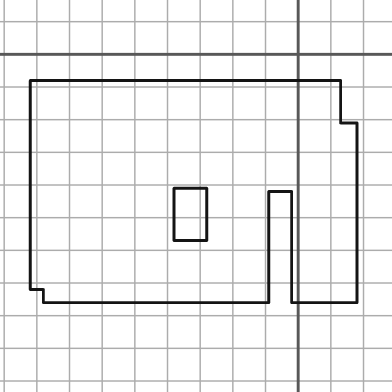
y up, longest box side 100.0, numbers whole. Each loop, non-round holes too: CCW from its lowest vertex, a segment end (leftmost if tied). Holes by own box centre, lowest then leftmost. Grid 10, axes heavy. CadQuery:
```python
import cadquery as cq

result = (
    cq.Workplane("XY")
    .moveTo(-78.0, -76.0)
    .lineTo(-9.0, -76.0)
    .lineTo(-9.0, -42.0)
    .lineTo(-2.0, -42.0)
    .lineTo(-2.0, -76.0)
    .lineTo(18.0, -76.0)
    .lineTo(18.0, -21.0)
    .lineTo(13.0, -21.0)
    .lineTo(13.0, -8.0)
    .lineTo(-82.0, -8.0)
    .lineTo(-82.0, -72.0)
    .lineTo(-78.0, -72.0)
    .close()
    .moveTo(-38.0, -57.0)
    .lineTo(-28.0, -57.0)
    .lineTo(-28.0, -41.0)
    .lineTo(-38.0, -41.0)
    .close()
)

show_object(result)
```